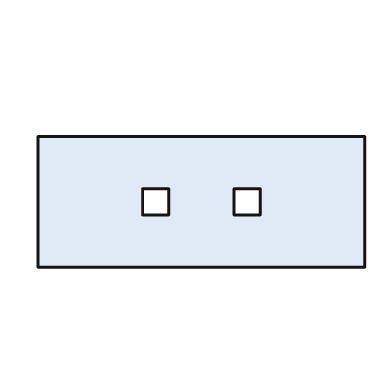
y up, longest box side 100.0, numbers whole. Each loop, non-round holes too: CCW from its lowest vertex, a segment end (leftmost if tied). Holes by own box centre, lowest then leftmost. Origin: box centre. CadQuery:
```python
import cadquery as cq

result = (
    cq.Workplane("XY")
    .moveTo(-50.0, -20.0)
    .lineTo(50.0, -20.0)
    .lineTo(50.0, 20.0)
    .lineTo(-50.0, 20.0)
    .close()
    .moveTo(-18.0, -4.0)
    .lineTo(-10.0, -4.0)
    .lineTo(-10.0, 4.0)
    .lineTo(-18.0, 4.0)
    .close()
    .moveTo(10.0, -4.0)
    .lineTo(18.0, -4.0)
    .lineTo(18.0, 4.0)
    .lineTo(10.0, 4.0)
    .close()
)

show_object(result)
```